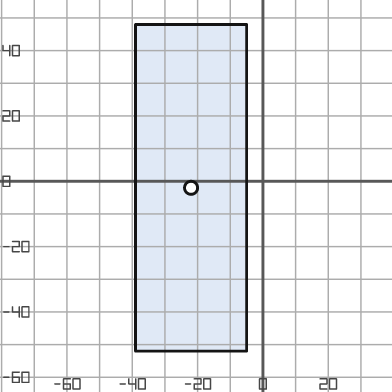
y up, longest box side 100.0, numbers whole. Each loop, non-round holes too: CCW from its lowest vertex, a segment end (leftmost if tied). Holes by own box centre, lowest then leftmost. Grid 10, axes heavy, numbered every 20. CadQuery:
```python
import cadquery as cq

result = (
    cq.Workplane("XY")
    .moveTo(-39.0, -52.0)
    .lineTo(-5.0, -52.0)
    .lineTo(-5.0, 48.0)
    .lineTo(-39.0, 48.0)
    .close()
    .moveTo(-22.0, -2.0)
    .circle(2.0)
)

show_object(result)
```